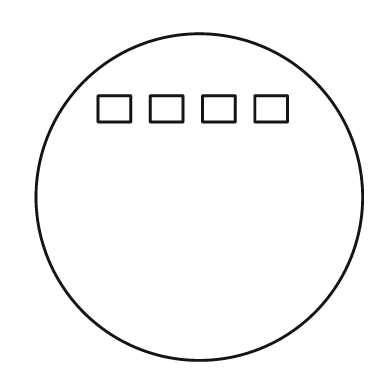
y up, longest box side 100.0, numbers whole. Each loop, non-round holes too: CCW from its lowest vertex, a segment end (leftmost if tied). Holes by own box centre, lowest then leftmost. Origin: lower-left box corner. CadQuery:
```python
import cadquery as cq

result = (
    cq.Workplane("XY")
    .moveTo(50.0, 50.0)
    .circle(50.0)
    .moveTo(19.0, 73.0)
    .lineTo(29.0, 73.0)
    .lineTo(29.0, 81.0)
    .lineTo(19.0, 81.0)
    .close()
    .moveTo(35.0, 73.0)
    .lineTo(45.0, 73.0)
    .lineTo(45.0, 81.0)
    .lineTo(35.0, 81.0)
    .close()
    .moveTo(51.0, 73.0)
    .lineTo(61.0, 73.0)
    .lineTo(61.0, 81.0)
    .lineTo(51.0, 81.0)
    .close()
    .moveTo(67.0, 73.0)
    .lineTo(77.0, 73.0)
    .lineTo(77.0, 81.0)
    .lineTo(67.0, 81.0)
    .close()
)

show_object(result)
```